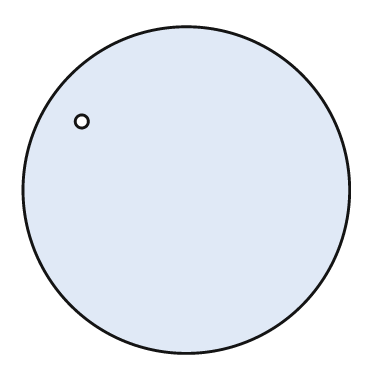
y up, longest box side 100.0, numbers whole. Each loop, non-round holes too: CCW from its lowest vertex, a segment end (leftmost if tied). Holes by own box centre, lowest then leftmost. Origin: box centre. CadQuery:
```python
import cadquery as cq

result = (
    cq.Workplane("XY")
    .moveTo(0.0, 0.0)
    .circle(50.0)
    .moveTo(-32.0, 21.0)
    .circle(2.0)
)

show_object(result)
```